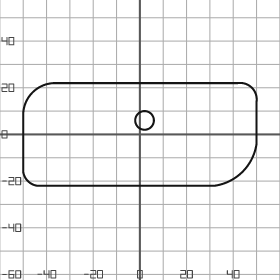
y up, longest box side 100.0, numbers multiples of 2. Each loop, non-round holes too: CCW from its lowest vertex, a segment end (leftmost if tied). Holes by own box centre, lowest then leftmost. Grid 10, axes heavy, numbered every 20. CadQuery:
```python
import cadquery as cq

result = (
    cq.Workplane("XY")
    .moveTo(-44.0, -22.0)
    .lineTo(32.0, -22.0)
    .threePointArc((44.0, -16.0), (50.0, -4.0))
    .lineTo(50.0, 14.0)
    .threePointArc((48.0, 20.0), (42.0, 22.0))
    .lineTo(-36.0, 22.0)
    .threePointArc((-46.0, 18.0), (-50.0, 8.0))
    .lineTo(-50.0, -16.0)
    .threePointArc((-48.0, -20.0), (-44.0, -22.0))
    .close()
    .moveTo(2.0, 6.0)
    .circle(4.0)
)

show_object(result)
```